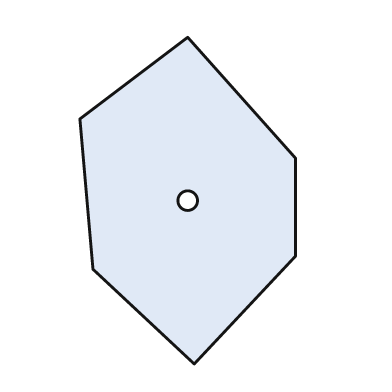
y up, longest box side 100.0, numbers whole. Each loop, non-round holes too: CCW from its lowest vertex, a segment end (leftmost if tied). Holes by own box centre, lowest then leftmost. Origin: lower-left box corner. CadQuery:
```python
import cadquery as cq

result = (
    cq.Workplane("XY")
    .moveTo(35.0, 0.0)
    .lineTo(66.0, 33.0)
    .lineTo(66.0, 63.0)
    .lineTo(33.0, 100.0)
    .lineTo(0.0, 75.0)
    .lineTo(4.0, 29.0)
    .close()
    .moveTo(33.0, 50.0)
    .circle(3.0)
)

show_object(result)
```